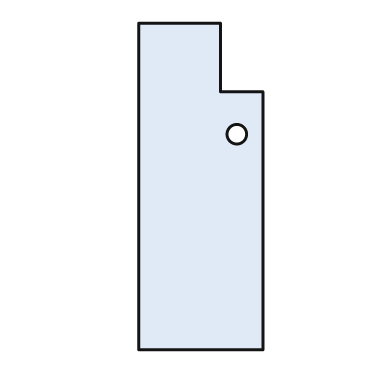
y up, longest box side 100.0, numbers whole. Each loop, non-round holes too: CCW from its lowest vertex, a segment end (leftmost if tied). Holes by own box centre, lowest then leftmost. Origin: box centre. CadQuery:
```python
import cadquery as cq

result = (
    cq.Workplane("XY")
    .moveTo(-19.0, -50.0)
    .lineTo(19.0, -50.0)
    .lineTo(19.0, 29.0)
    .lineTo(6.0, 29.0)
    .lineTo(6.0, 50.0)
    .lineTo(-19.0, 50.0)
    .close()
    .moveTo(11.0, 16.0)
    .circle(3.0)
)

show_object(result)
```